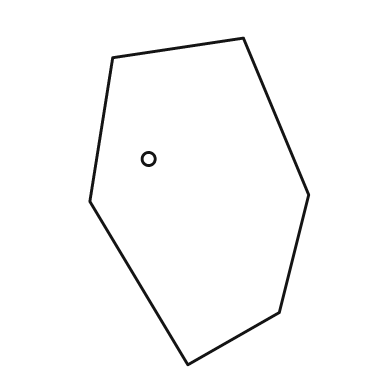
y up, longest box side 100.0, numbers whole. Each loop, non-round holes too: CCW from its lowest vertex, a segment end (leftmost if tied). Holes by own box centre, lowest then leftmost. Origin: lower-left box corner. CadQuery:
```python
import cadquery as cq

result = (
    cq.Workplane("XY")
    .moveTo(30.0, 0.0)
    .lineTo(58.0, 16.0)
    .lineTo(67.0, 52.0)
    .lineTo(47.0, 100.0)
    .lineTo(7.0, 94.0)
    .lineTo(0.0, 50.0)
    .close()
    .moveTo(18.0, 63.0)
    .circle(2.0)
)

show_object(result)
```